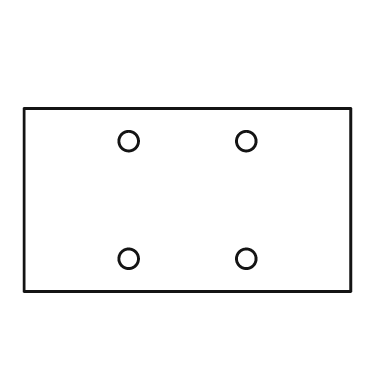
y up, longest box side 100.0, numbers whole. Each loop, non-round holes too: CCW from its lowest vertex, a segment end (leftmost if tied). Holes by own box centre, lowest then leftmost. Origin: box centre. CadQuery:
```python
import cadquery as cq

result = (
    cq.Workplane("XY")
    .moveTo(-50.0, -28.0)
    .lineTo(50.0, -28.0)
    .lineTo(50.0, 28.0)
    .lineTo(-50.0, 28.0)
    .close()
    .moveTo(-18.0, -18.0)
    .circle(3.0)
    .moveTo(18.0, -18.0)
    .circle(3.0)
    .moveTo(-18.0, 18.0)
    .circle(3.0)
    .moveTo(18.0, 18.0)
    .circle(3.0)
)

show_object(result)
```